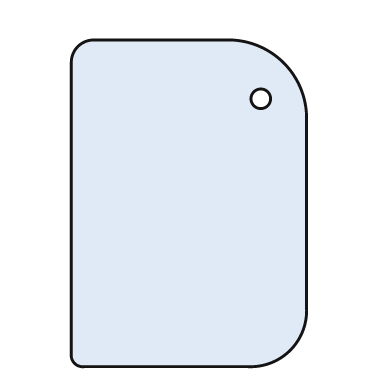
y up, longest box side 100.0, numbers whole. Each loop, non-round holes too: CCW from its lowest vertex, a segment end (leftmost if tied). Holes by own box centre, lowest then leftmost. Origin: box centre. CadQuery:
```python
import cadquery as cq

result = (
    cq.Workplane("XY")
    .moveTo(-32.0, -50.0)
    .lineTo(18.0, -50.0)
    .threePointArc((31.0, -45.0), (36.0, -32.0))
    .lineTo(36.0, 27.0)
    .threePointArc((29.0, 43.0), (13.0, 50.0))
    .lineTo(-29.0, 50.0)
    .threePointArc((-34.0, 48.0), (-36.0, 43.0))
    .lineTo(-36.0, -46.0)
    .threePointArc((-35.0, -49.0), (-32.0, -50.0))
    .close()
    .moveTo(22.0, 32.0)
    .circle(3.0)
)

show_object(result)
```